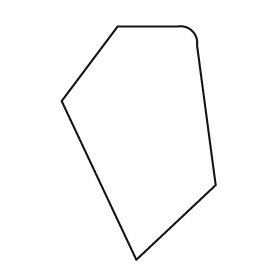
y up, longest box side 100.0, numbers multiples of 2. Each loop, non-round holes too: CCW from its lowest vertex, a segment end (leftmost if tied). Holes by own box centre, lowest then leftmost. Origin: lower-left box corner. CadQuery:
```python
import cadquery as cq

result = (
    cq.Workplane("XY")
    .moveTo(32.0, 0.0)
    .lineTo(66.0, 32.0)
    .lineTo(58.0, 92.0)
    .threePointArc((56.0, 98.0), (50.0, 100.0))
    .lineTo(24.0, 100.0)
    .lineTo(0.0, 68.0)
    .close()
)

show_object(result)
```